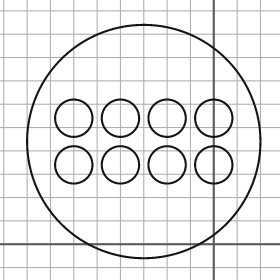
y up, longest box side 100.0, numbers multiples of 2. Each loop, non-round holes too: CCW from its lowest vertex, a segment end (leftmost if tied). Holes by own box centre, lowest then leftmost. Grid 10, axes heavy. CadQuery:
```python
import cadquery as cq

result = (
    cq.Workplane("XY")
    .moveTo(-30.0, 44.0)
    .circle(50.0)
    .moveTo(-60.0, 34.0)
    .circle(8.0)
    .moveTo(-40.0, 34.0)
    .circle(8.0)
    .moveTo(-20.0, 34.0)
    .circle(8.0)
    .moveTo(0.0, 34.0)
    .circle(8.0)
    .moveTo(-60.0, 54.0)
    .circle(8.0)
    .moveTo(-40.0, 54.0)
    .circle(8.0)
    .moveTo(-20.0, 54.0)
    .circle(8.0)
    .moveTo(0.0, 54.0)
    .circle(8.0)
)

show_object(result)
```